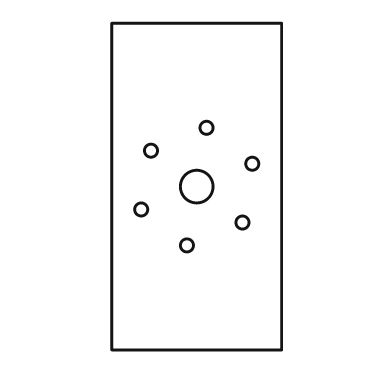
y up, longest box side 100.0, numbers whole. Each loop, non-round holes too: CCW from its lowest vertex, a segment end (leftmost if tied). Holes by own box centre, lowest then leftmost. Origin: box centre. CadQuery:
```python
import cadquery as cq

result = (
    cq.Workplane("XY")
    .moveTo(-26.0, -50.0)
    .lineTo(26.0, -50.0)
    .lineTo(26.0, 50.0)
    .lineTo(-26.0, 50.0)
    .close()
    .moveTo(-3.0, -18.0)
    .circle(2.0)
    .moveTo(14.0, -11.0)
    .circle(2.0)
    .moveTo(-17.0, -7.0)
    .circle(2.0)
    .moveTo(0.0, 0.0)
    .circle(5.0)
    .moveTo(17.0, 7.0)
    .circle(2.0)
    .moveTo(-14.0, 11.0)
    .circle(2.0)
    .moveTo(3.0, 18.0)
    .circle(2.0)
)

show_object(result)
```